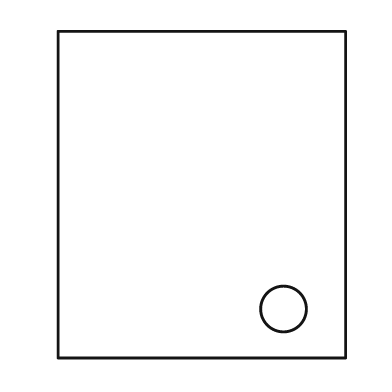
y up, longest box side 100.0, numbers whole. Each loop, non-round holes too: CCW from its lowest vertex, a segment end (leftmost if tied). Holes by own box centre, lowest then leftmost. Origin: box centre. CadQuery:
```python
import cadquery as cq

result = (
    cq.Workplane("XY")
    .moveTo(-44.0, -50.0)
    .lineTo(44.0, -50.0)
    .lineTo(44.0, 50.0)
    .lineTo(-44.0, 50.0)
    .close()
    .moveTo(25.0, -35.0)
    .circle(7.0)
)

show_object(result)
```